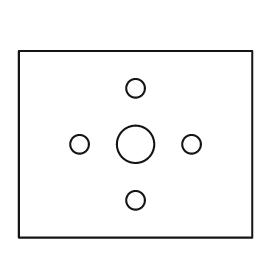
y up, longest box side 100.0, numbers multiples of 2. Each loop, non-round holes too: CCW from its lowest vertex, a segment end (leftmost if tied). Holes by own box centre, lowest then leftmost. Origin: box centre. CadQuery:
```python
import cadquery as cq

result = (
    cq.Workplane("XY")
    .moveTo(-50.0, -40.0)
    .lineTo(50.0, -40.0)
    .lineTo(50.0, 40.0)
    .lineTo(-50.0, 40.0)
    .close()
    .moveTo(0.0, -24.0)
    .circle(4.0)
    .moveTo(-24.0, 0.0)
    .circle(4.0)
    .moveTo(0.0, 0.0)
    .circle(8.0)
    .moveTo(24.0, 0.0)
    .circle(4.0)
    .moveTo(0.0, 24.0)
    .circle(4.0)
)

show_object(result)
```